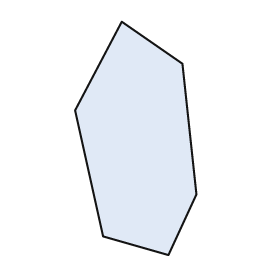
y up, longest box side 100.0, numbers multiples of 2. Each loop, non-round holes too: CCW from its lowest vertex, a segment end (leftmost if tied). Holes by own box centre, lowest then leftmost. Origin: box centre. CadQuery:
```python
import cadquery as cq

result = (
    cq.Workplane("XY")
    .moveTo(14.0, -50.0)
    .lineTo(26.0, -24.0)
    .lineTo(20.0, 32.0)
    .lineTo(-6.0, 50.0)
    .lineTo(-26.0, 12.0)
    .lineTo(-14.0, -42.0)
    .close()
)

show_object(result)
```